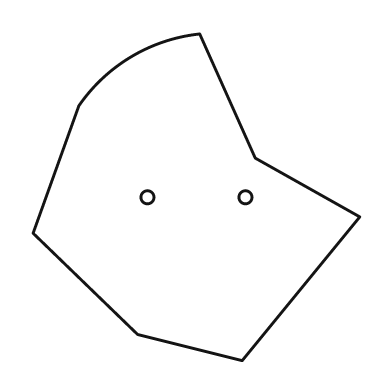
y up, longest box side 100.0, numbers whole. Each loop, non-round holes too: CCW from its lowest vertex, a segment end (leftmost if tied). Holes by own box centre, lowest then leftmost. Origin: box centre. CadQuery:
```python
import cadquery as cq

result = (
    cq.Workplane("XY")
    .moveTo(14.0, -50.0)
    .lineTo(50.0, -6.0)
    .lineTo(18.0, 12.0)
    .lineTo(1.0, 50.0)
    .threePointArc((-20.0, 43.0), (-36.0, 28.0))
    .lineTo(-50.0, -11.0)
    .lineTo(-18.0, -42.0)
    .close()
    .moveTo(-15.0, 0.0)
    .circle(2.0)
    .moveTo(15.0, 0.0)
    .circle(2.0)
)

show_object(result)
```